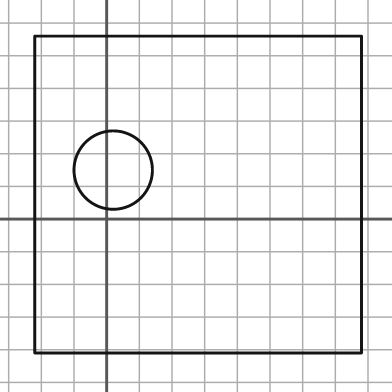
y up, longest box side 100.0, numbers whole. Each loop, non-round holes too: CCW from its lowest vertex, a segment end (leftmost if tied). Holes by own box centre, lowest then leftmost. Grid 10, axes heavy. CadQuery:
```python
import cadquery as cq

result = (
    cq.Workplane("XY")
    .moveTo(-22.0, -41.0)
    .lineTo(78.0, -41.0)
    .lineTo(78.0, 56.0)
    .lineTo(-22.0, 56.0)
    .close()
    .moveTo(2.0, 15.0)
    .circle(12.0)
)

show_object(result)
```